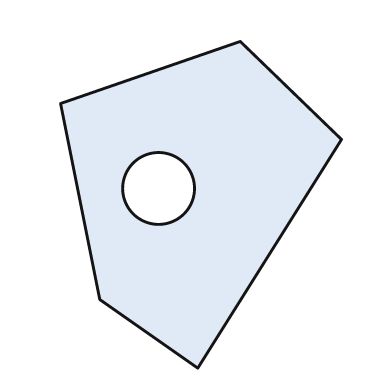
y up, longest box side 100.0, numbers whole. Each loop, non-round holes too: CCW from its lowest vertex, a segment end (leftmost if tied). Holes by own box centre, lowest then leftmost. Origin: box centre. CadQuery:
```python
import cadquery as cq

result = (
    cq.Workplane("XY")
    .moveTo(-1.0, -50.0)
    .lineTo(43.0, 20.0)
    .lineTo(12.0, 50.0)
    .lineTo(-43.0, 31.0)
    .lineTo(-31.0, -29.0)
    .close()
    .moveTo(-13.0, 5.0)
    .circle(11.0)
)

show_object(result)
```